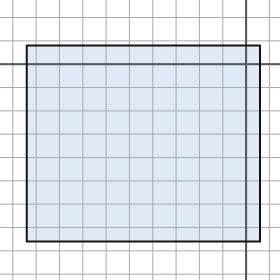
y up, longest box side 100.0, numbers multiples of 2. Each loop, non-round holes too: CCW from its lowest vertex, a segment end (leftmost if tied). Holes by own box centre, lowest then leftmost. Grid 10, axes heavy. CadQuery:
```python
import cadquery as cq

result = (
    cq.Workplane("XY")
    .moveTo(-94.0, -76.0)
    .lineTo(6.0, -76.0)
    .lineTo(6.0, 8.0)
    .lineTo(-94.0, 8.0)
    .close()
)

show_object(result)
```